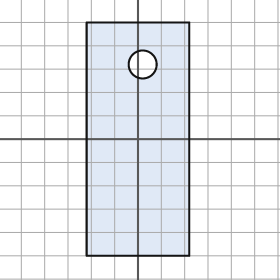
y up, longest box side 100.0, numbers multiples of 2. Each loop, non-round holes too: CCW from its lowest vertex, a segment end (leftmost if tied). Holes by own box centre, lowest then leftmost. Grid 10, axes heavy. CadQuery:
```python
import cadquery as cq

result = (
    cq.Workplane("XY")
    .moveTo(-22.0, -50.0)
    .lineTo(22.0, -50.0)
    .lineTo(22.0, 50.0)
    .lineTo(-22.0, 50.0)
    .close()
    .moveTo(2.0, 32.0)
    .circle(6.0)
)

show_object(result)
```